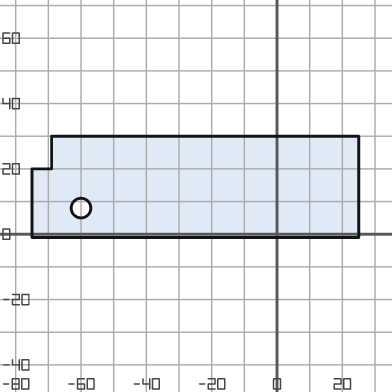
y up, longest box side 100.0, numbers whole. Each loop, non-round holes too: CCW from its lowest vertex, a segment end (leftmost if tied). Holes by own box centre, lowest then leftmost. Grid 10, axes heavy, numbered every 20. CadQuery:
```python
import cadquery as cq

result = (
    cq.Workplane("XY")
    .moveTo(-75.0, -1.0)
    .lineTo(25.0, -1.0)
    .lineTo(25.0, 30.0)
    .lineTo(-69.0, 30.0)
    .lineTo(-69.0, 20.0)
    .lineTo(-75.0, 20.0)
    .close()
    .moveTo(-60.0, 8.0)
    .circle(3.0)
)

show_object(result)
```